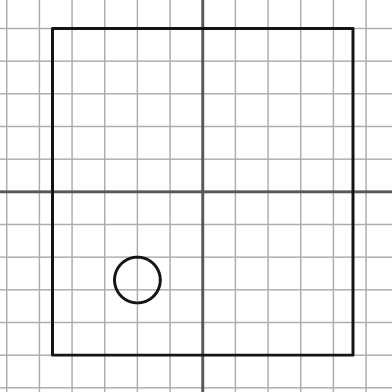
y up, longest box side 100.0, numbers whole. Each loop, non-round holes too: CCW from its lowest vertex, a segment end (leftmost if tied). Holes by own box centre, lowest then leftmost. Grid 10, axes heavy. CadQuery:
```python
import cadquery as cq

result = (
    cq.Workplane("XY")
    .moveTo(-46.0, -50.0)
    .lineTo(46.0, -50.0)
    .lineTo(46.0, 50.0)
    .lineTo(-46.0, 50.0)
    .close()
    .moveTo(-20.0, -27.0)
    .circle(7.0)
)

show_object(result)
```